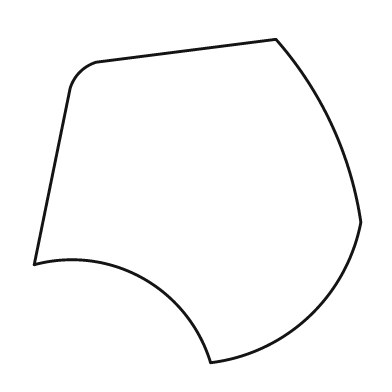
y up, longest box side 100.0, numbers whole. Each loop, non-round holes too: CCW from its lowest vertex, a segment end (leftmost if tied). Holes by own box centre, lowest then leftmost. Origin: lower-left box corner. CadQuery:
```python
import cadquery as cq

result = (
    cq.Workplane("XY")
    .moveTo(54.0, 0.0)
    .threePointArc((84.0, 14.0), (100.0, 43.0))
    .threePointArc((91.0, 73.0), (74.0, 99.0))
    .lineTo(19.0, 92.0)
    .threePointArc((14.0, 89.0), (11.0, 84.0))
    .lineTo(0.0, 30.0)
    .threePointArc((33.0, 26.0), (54.0, 0.0))
    .close()
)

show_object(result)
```